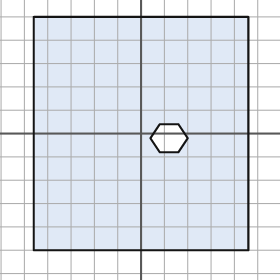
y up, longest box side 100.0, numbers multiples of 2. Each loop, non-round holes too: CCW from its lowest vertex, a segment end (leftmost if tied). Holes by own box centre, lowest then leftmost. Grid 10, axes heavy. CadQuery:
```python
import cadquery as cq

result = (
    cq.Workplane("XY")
    .moveTo(-46.0, -50.0)
    .lineTo(46.0, -50.0)
    .lineTo(46.0, 50.0)
    .lineTo(-46.0, 50.0)
    .close()
    .moveTo(8.0, -8.0)
    .lineTo(16.0, -8.0)
    .lineTo(20.0, -2.0)
    .lineTo(16.0, 4.0)
    .lineTo(8.0, 4.0)
    .lineTo(4.0, -2.0)
    .close()
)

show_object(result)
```